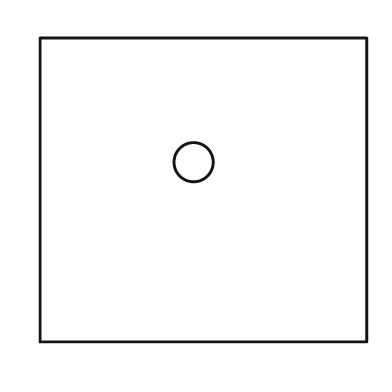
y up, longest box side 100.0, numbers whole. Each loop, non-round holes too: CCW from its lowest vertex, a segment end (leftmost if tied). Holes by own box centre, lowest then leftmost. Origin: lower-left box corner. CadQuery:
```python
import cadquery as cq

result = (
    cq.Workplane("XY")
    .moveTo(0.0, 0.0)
    .lineTo(100.0, 0.0)
    .lineTo(100.0, 93.0)
    .lineTo(0.0, 93.0)
    .close()
    .moveTo(47.0, 55.0)
    .circle(6.0)
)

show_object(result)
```